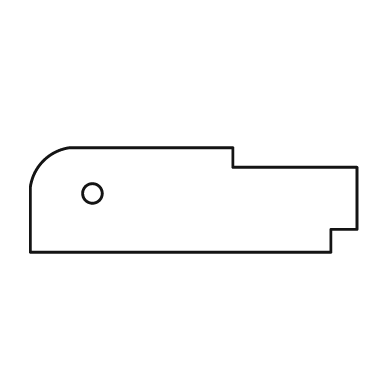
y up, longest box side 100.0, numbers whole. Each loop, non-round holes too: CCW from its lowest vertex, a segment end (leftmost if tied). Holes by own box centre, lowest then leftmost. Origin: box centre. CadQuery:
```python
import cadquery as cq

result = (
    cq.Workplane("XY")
    .moveTo(-50.0, -16.0)
    .lineTo(42.0, -16.0)
    .lineTo(42.0, -9.0)
    .lineTo(50.0, -9.0)
    .lineTo(50.0, 10.0)
    .lineTo(12.0, 10.0)
    .lineTo(12.0, 16.0)
    .lineTo(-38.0, 16.0)
    .threePointArc((-46.0, 12.0), (-50.0, 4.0))
    .close()
    .moveTo(-31.0, 2.0)
    .circle(3.0)
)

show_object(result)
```